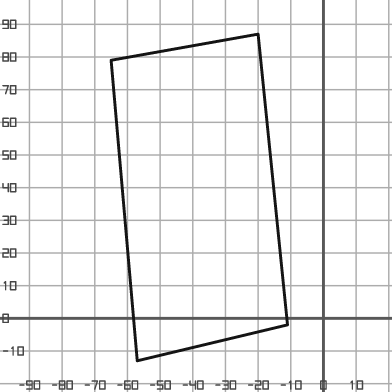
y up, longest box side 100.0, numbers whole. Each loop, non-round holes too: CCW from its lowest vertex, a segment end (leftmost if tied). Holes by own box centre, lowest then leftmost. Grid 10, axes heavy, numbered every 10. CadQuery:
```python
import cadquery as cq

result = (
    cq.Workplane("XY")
    .moveTo(-57.0, -13.0)
    .lineTo(-11.0, -2.0)
    .lineTo(-20.0, 87.0)
    .lineTo(-65.0, 79.0)
    .close()
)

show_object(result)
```